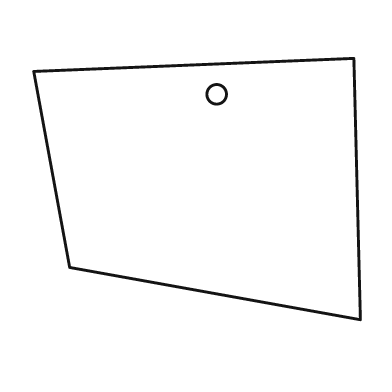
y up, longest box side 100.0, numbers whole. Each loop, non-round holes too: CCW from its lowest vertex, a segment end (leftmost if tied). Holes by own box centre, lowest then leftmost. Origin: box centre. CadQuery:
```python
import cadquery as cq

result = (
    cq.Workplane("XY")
    .moveTo(50.0, -40.0)
    .lineTo(48.0, 40.0)
    .lineTo(-50.0, 36.0)
    .lineTo(-39.0, -24.0)
    .close()
    .moveTo(6.0, 29.0)
    .circle(3.0)
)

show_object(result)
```